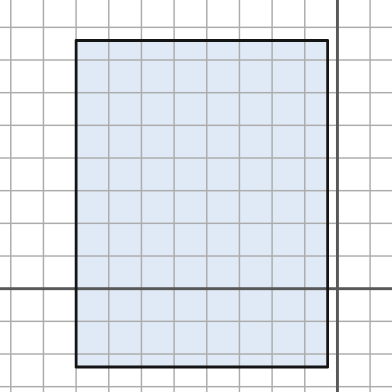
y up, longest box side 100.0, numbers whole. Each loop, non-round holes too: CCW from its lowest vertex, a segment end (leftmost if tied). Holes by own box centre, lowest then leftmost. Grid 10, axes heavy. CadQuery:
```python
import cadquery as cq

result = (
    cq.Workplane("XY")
    .moveTo(-80.0, -24.0)
    .lineTo(-3.0, -24.0)
    .lineTo(-3.0, 76.0)
    .lineTo(-80.0, 76.0)
    .close()
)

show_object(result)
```